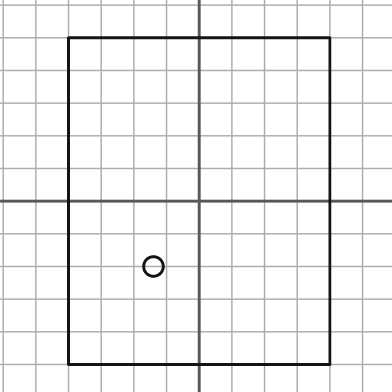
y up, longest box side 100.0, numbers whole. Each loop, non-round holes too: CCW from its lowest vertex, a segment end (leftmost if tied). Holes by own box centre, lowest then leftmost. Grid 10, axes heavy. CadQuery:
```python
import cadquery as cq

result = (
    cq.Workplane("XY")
    .moveTo(-40.0, -50.0)
    .lineTo(40.0, -50.0)
    .lineTo(40.0, 50.0)
    .lineTo(-40.0, 50.0)
    .close()
    .moveTo(-14.0, -20.0)
    .circle(3.0)
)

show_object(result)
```